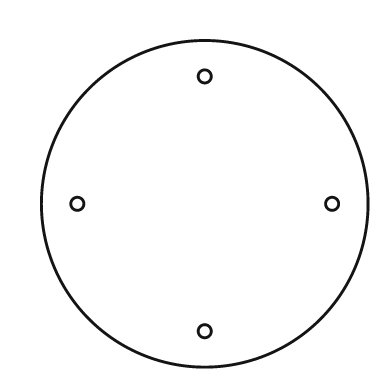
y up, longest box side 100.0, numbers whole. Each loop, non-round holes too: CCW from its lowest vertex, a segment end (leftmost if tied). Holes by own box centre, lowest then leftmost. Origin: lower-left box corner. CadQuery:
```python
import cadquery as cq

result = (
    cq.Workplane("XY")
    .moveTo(50.0, 50.0)
    .circle(50.0)
    .moveTo(50.0, 11.0)
    .circle(2.0)
    .moveTo(11.0, 50.0)
    .circle(2.0)
    .moveTo(89.0, 50.0)
    .circle(2.0)
    .moveTo(50.0, 89.0)
    .circle(2.0)
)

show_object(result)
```